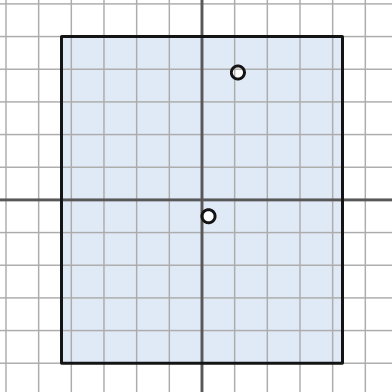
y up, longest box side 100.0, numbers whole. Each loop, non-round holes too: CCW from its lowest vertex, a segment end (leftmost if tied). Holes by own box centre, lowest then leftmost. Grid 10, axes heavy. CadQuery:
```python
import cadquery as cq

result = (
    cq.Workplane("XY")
    .moveTo(-43.0, -50.0)
    .lineTo(43.0, -50.0)
    .lineTo(43.0, 50.0)
    .lineTo(-43.0, 50.0)
    .close()
    .moveTo(2.0, -5.0)
    .circle(2.0)
    .moveTo(11.0, 39.0)
    .circle(2.0)
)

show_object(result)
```